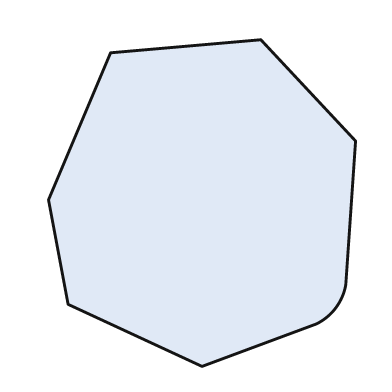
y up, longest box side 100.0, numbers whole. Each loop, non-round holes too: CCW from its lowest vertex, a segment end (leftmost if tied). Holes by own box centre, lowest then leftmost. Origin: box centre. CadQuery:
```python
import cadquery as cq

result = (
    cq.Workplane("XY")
    .moveTo(0.0, -50.0)
    .lineTo(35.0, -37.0)
    .threePointArc((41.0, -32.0), (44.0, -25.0))
    .lineTo(47.0, 19.0)
    .lineTo(18.0, 50.0)
    .lineTo(-28.0, 46.0)
    .lineTo(-47.0, 1.0)
    .lineTo(-41.0, -31.0)
    .close()
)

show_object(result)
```